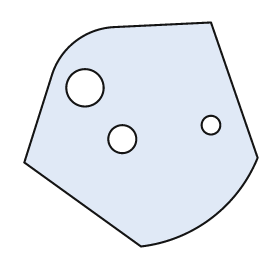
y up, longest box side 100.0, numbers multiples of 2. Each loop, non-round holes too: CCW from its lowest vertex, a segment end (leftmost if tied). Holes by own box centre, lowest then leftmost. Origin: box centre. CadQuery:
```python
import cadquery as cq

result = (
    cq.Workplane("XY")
    .moveTo(0.0, -48.0)
    .threePointArc((30.0, -36.0), (50.0, -10.0))
    .lineTo(30.0, 48.0)
    .lineTo(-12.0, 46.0)
    .threePointArc((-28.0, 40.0), (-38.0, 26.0))
    .lineTo(-50.0, -12.0)
    .close()
    .moveTo(-8.0, -2.0)
    .circle(6.0)
    .moveTo(30.0, 4.0)
    .circle(4.0)
    .moveTo(-24.0, 20.0)
    .circle(8.0)
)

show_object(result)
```